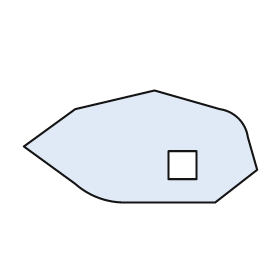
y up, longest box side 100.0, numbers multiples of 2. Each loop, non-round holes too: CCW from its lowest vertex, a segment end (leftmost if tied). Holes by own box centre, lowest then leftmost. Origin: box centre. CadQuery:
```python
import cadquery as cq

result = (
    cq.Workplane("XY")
    .moveTo(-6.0, -24.0)
    .lineTo(32.0, -24.0)
    .lineTo(50.0, -10.0)
    .lineTo(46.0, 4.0)
    .threePointArc((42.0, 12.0), (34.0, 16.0))
    .lineTo(6.0, 24.0)
    .lineTo(-28.0, 16.0)
    .lineTo(-50.0, 0.0)
    .lineTo(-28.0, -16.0)
    .threePointArc((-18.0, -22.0), (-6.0, -24.0))
    .close()
    .moveTo(12.0, -14.0)
    .lineTo(24.0, -14.0)
    .lineTo(24.0, -2.0)
    .lineTo(12.0, -2.0)
    .close()
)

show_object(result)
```